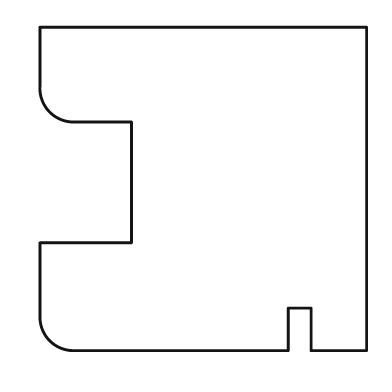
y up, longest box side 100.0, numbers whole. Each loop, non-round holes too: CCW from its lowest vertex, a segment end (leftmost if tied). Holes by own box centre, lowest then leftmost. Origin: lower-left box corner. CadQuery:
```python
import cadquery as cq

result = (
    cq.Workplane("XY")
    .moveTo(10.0, 0.0)
    .lineTo(76.0, 0.0)
    .lineTo(76.0, 13.0)
    .lineTo(83.0, 13.0)
    .lineTo(83.0, 0.0)
    .lineTo(100.0, 0.0)
    .lineTo(100.0, 99.0)
    .lineTo(0.0, 99.0)
    .lineTo(0.0, 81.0)
    .threePointArc((3.0, 73.0), (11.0, 70.0))
    .lineTo(28.0, 70.0)
    .lineTo(28.0, 33.0)
    .lineTo(0.0, 33.0)
    .lineTo(0.0, 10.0)
    .threePointArc((3.0, 3.0), (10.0, 0.0))
    .close()
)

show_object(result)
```